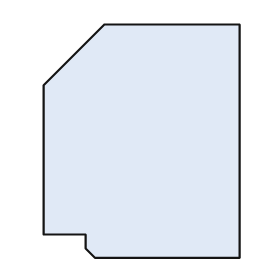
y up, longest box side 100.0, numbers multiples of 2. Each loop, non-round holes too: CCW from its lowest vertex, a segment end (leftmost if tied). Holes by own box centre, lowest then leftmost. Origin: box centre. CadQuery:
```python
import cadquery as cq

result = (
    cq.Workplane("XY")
    .moveTo(-20.0, -50.0)
    .lineTo(42.0, -50.0)
    .lineTo(42.0, 50.0)
    .lineTo(-16.0, 50.0)
    .lineTo(-42.0, 24.0)
    .lineTo(-42.0, -40.0)
    .lineTo(-24.0, -40.0)
    .lineTo(-24.0, -46.0)
    .close()
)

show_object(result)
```